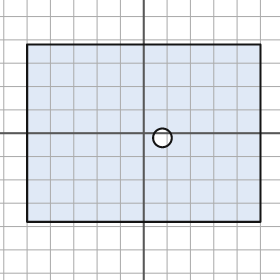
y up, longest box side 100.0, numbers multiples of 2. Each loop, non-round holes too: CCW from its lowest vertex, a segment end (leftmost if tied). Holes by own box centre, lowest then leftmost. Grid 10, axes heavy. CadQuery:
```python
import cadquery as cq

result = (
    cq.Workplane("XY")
    .moveTo(-50.0, -38.0)
    .lineTo(50.0, -38.0)
    .lineTo(50.0, 38.0)
    .lineTo(-50.0, 38.0)
    .close()
    .moveTo(8.0, -2.0)
    .circle(4.0)
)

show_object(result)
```